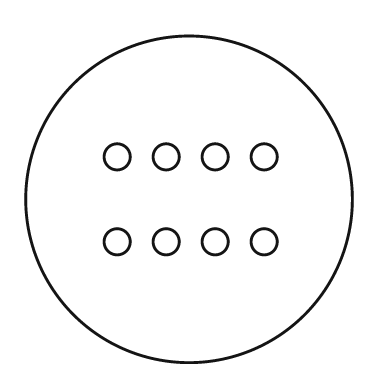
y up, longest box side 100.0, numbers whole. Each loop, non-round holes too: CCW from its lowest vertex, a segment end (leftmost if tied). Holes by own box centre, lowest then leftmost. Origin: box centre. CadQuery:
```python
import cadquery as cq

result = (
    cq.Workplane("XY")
    .moveTo(0.0, 0.0)
    .circle(50.0)
    .moveTo(-22.0, -13.0)
    .circle(4.0)
    .moveTo(-7.0, -13.0)
    .circle(4.0)
    .moveTo(8.0, -13.0)
    .circle(4.0)
    .moveTo(23.0, -13.0)
    .circle(4.0)
    .moveTo(-22.0, 13.0)
    .circle(4.0)
    .moveTo(-7.0, 13.0)
    .circle(4.0)
    .moveTo(8.0, 13.0)
    .circle(4.0)
    .moveTo(23.0, 13.0)
    .circle(4.0)
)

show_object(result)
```